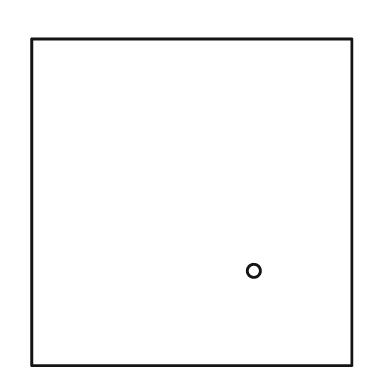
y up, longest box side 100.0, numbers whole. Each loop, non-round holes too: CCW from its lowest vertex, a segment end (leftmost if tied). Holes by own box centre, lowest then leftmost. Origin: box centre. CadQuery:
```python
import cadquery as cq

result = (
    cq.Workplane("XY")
    .moveTo(-49.0, -50.0)
    .lineTo(49.0, -50.0)
    .lineTo(49.0, 50.0)
    .lineTo(-49.0, 50.0)
    .close()
    .moveTo(19.0, -21.0)
    .circle(2.0)
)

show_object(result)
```